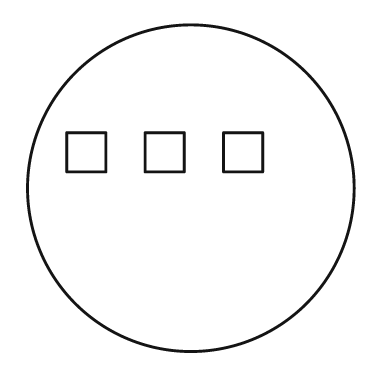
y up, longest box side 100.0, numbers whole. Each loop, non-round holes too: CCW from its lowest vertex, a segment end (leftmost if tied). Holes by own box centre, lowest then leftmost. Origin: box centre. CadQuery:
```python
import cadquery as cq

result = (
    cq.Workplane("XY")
    .moveTo(0.0, 0.0)
    .circle(50.0)
    .moveTo(-38.0, 5.0)
    .lineTo(-26.0, 5.0)
    .lineTo(-26.0, 17.0)
    .lineTo(-38.0, 17.0)
    .close()
    .moveTo(-14.0, 5.0)
    .lineTo(-2.0, 5.0)
    .lineTo(-2.0, 17.0)
    .lineTo(-14.0, 17.0)
    .close()
    .moveTo(10.0, 5.0)
    .lineTo(22.0, 5.0)
    .lineTo(22.0, 17.0)
    .lineTo(10.0, 17.0)
    .close()
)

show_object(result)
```